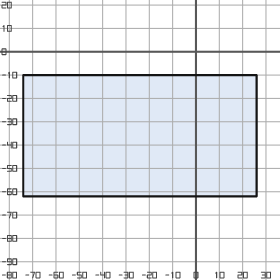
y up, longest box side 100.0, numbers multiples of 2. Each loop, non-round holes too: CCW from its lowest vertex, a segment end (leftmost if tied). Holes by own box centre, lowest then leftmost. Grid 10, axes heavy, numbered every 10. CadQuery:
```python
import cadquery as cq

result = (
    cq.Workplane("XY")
    .moveTo(-74.0, -62.0)
    .lineTo(26.0, -62.0)
    .lineTo(26.0, -10.0)
    .lineTo(-74.0, -10.0)
    .close()
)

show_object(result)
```